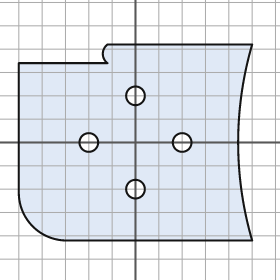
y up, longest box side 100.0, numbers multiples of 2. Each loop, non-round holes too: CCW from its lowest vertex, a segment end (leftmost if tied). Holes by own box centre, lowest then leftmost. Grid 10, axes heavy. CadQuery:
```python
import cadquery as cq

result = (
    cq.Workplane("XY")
    .moveTo(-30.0, -42.0)
    .lineTo(50.0, -42.0)
    .threePointArc((44.0, 0.0), (50.0, 42.0))
    .lineTo(-12.0, 42.0)
    .threePointArc((-14.0, 38.0), (-12.0, 34.0))
    .lineTo(-50.0, 34.0)
    .lineTo(-50.0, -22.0)
    .threePointArc((-44.0, -36.0), (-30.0, -42.0))
    .close()
    .moveTo(0.0, -20.0)
    .circle(4.0)
    .moveTo(-20.0, 0.0)
    .circle(4.0)
    .moveTo(20.0, 0.0)
    .circle(4.0)
    .moveTo(0.0, 20.0)
    .circle(4.0)
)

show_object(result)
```